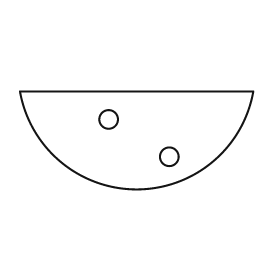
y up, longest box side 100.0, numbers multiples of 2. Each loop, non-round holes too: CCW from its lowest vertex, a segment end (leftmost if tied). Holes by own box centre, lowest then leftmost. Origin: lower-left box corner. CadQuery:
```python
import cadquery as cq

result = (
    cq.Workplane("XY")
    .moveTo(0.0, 42.0)
    .threePointArc((50.0, 0.0), (100.0, 42.0))
    .close()
    .moveTo(64.0, 14.0)
    .circle(4.0)
    .moveTo(38.0, 30.0)
    .circle(4.0)
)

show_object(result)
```